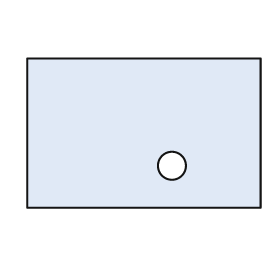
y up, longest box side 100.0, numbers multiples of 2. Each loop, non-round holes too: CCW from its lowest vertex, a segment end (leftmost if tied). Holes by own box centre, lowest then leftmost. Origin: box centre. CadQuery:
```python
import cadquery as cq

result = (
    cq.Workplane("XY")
    .moveTo(-50.0, -32.0)
    .lineTo(50.0, -32.0)
    .lineTo(50.0, 32.0)
    .lineTo(-50.0, 32.0)
    .close()
    .moveTo(12.0, -14.0)
    .circle(6.0)
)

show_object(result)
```